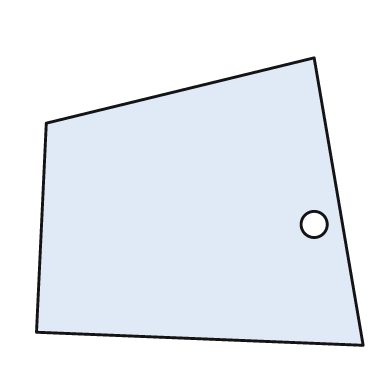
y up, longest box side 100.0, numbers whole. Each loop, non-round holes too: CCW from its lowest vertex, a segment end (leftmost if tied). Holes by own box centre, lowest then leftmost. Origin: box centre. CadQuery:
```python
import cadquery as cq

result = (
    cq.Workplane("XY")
    .moveTo(50.0, -44.0)
    .lineTo(35.0, 44.0)
    .lineTo(-47.0, 24.0)
    .lineTo(-50.0, -40.0)
    .close()
    .moveTo(35.0, -7.0)
    .circle(4.0)
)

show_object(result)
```